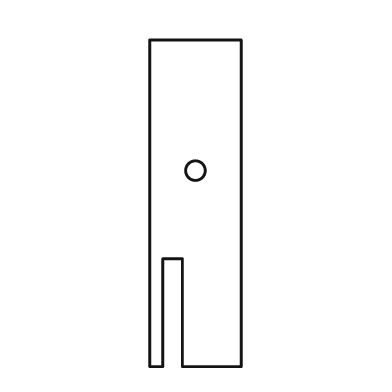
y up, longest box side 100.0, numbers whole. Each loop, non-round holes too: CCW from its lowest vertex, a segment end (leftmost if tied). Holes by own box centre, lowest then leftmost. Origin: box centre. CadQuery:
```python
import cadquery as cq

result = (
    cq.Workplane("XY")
    .moveTo(-14.0, -50.0)
    .lineTo(-10.0, -50.0)
    .lineTo(-10.0, -17.0)
    .lineTo(-4.0, -17.0)
    .lineTo(-4.0, -50.0)
    .lineTo(14.0, -50.0)
    .lineTo(14.0, 50.0)
    .lineTo(-14.0, 50.0)
    .close()
    .moveTo(0.0, 10.0)
    .circle(3.0)
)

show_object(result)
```